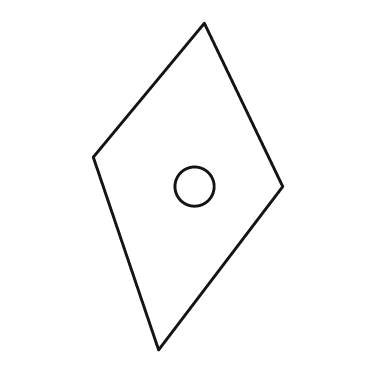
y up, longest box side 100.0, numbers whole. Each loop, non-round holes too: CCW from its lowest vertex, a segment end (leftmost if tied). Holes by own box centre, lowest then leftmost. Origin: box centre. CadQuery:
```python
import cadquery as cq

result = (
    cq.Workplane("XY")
    .moveTo(-9.0, -50.0)
    .lineTo(29.0, 0.0)
    .lineTo(5.0, 50.0)
    .lineTo(-29.0, 9.0)
    .close()
    .moveTo(2.0, 0.0)
    .circle(6.0)
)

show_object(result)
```